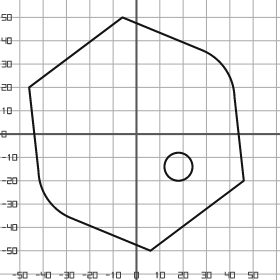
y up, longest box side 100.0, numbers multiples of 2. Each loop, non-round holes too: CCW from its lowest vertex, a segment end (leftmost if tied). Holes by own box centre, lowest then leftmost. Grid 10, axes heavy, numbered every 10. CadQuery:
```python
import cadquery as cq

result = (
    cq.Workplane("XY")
    .moveTo(6.0, -50.0)
    .lineTo(46.0, -20.0)
    .lineTo(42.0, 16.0)
    .threePointArc((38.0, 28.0), (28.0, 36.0))
    .lineTo(-6.0, 50.0)
    .lineTo(-46.0, 20.0)
    .lineTo(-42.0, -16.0)
    .threePointArc((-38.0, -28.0), (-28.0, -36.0))
    .close()
    .moveTo(18.0, -14.0)
    .circle(6.0)
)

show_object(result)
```